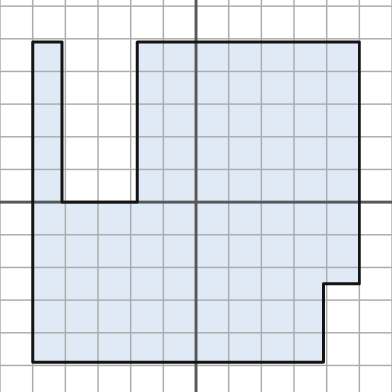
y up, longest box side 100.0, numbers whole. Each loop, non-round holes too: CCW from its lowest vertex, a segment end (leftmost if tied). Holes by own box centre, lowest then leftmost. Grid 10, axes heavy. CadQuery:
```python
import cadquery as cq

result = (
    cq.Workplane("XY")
    .moveTo(-50.0, -49.0)
    .lineTo(39.0, -49.0)
    .lineTo(39.0, -25.0)
    .lineTo(50.0, -25.0)
    .lineTo(50.0, 49.0)
    .lineTo(-18.0, 49.0)
    .lineTo(-18.0, 0.0)
    .lineTo(-41.0, 0.0)
    .lineTo(-41.0, 49.0)
    .lineTo(-50.0, 49.0)
    .close()
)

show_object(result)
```